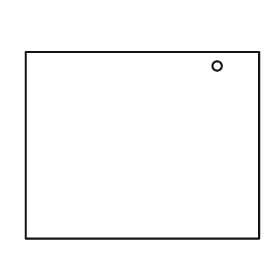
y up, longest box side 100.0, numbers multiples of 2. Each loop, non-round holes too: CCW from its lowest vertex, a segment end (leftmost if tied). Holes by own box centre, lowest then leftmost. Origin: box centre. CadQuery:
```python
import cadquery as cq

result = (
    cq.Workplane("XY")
    .moveTo(-50.0, -40.0)
    .lineTo(50.0, -40.0)
    .lineTo(50.0, 40.0)
    .lineTo(-50.0, 40.0)
    .close()
    .moveTo(32.0, 34.0)
    .circle(2.0)
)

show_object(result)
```